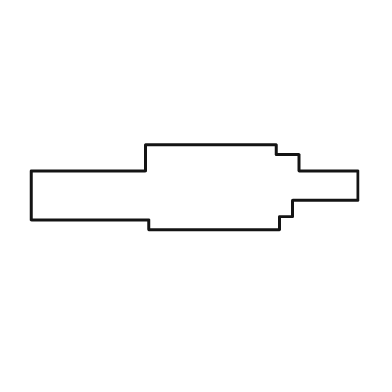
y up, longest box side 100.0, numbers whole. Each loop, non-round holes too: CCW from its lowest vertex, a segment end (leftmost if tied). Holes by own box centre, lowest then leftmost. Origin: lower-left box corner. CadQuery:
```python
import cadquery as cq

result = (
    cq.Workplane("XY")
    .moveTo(36.0, 0.0)
    .lineTo(76.0, 0.0)
    .lineTo(76.0, 4.0)
    .lineTo(80.0, 4.0)
    .lineTo(80.0, 9.0)
    .lineTo(100.0, 9.0)
    .lineTo(100.0, 18.0)
    .lineTo(82.0, 18.0)
    .lineTo(82.0, 23.0)
    .lineTo(75.0, 23.0)
    .lineTo(75.0, 26.0)
    .lineTo(35.0, 26.0)
    .lineTo(35.0, 18.0)
    .lineTo(0.0, 18.0)
    .lineTo(0.0, 3.0)
    .lineTo(36.0, 3.0)
    .close()
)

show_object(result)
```